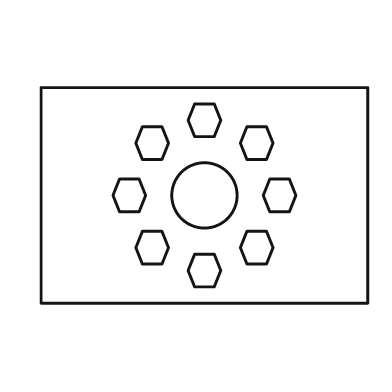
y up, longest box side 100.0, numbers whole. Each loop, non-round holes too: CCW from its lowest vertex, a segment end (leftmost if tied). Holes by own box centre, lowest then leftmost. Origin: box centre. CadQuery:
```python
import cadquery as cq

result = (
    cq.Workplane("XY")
    .moveTo(-50.0, -33.0)
    .lineTo(50.0, -33.0)
    .lineTo(50.0, 33.0)
    .lineTo(-50.0, 33.0)
    .close()
    .moveTo(-3.0, -28.0)
    .lineTo(3.0, -28.0)
    .lineTo(5.0, -23.0)
    .lineTo(3.0, -18.0)
    .lineTo(-3.0, -18.0)
    .lineTo(-5.0, -23.0)
    .close()
    .moveTo(-19.0, -21.0)
    .lineTo(-13.0, -21.0)
    .lineTo(-11.0, -16.0)
    .lineTo(-13.0, -11.0)
    .lineTo(-19.0, -11.0)
    .lineTo(-21.0, -16.0)
    .close()
    .moveTo(13.0, -21.0)
    .lineTo(19.0, -21.0)
    .lineTo(21.0, -16.0)
    .lineTo(19.0, -11.0)
    .lineTo(13.0, -11.0)
    .lineTo(11.0, -16.0)
    .close()
    .moveTo(-26.0, -5.0)
    .lineTo(-20.0, -5.0)
    .lineTo(-18.0, 0.0)
    .lineTo(-20.0, 5.0)
    .lineTo(-26.0, 5.0)
    .lineTo(-28.0, 0.0)
    .close()
    .moveTo(0.0, 0.0)
    .circle(10.0)
    .moveTo(20.0, -5.0)
    .lineTo(26.0, -5.0)
    .lineTo(28.0, 0.0)
    .lineTo(26.0, 5.0)
    .lineTo(20.0, 5.0)
    .lineTo(18.0, 0.0)
    .close()
    .moveTo(-19.0, 11.0)
    .lineTo(-13.0, 11.0)
    .lineTo(-11.0, 16.0)
    .lineTo(-13.0, 21.0)
    .lineTo(-19.0, 21.0)
    .lineTo(-21.0, 16.0)
    .close()
    .moveTo(13.0, 11.0)
    .lineTo(19.0, 11.0)
    .lineTo(21.0, 16.0)
    .lineTo(19.0, 21.0)
    .lineTo(13.0, 21.0)
    .lineTo(11.0, 16.0)
    .close()
    .moveTo(-3.0, 18.0)
    .lineTo(3.0, 18.0)
    .lineTo(5.0, 23.0)
    .lineTo(3.0, 28.0)
    .lineTo(-3.0, 28.0)
    .lineTo(-5.0, 23.0)
    .close()
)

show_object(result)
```